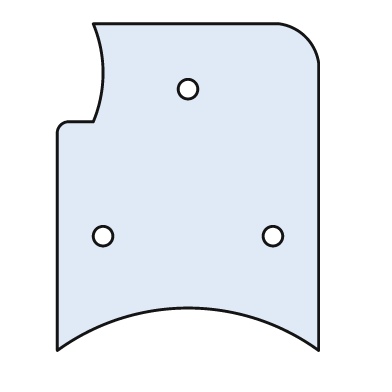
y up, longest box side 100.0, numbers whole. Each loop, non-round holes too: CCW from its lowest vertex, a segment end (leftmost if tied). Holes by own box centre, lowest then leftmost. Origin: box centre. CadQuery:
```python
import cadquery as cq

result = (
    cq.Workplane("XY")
    .moveTo(-40.0, -50.0)
    .threePointArc((0.0, -37.0), (40.0, -50.0))
    .lineTo(40.0, 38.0)
    .threePointArc((36.0, 46.0), (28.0, 50.0))
    .lineTo(-29.0, 50.0)
    .threePointArc((-26.0, 35.0), (-29.0, 20.0))
    .lineTo(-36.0, 20.0)
    .threePointArc((-39.0, 19.0), (-40.0, 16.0))
    .close()
    .moveTo(-26.0, -15.0)
    .circle(3.0)
    .moveTo(26.0, -15.0)
    .circle(3.0)
    .moveTo(0.0, 30.0)
    .circle(3.0)
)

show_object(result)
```